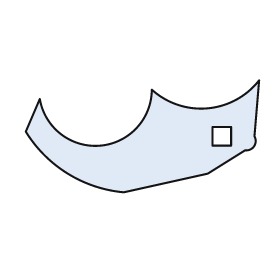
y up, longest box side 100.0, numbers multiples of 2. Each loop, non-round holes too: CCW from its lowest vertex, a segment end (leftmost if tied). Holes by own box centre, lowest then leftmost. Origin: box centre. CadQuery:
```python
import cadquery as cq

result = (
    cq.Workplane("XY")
    .moveTo(-8.0, -24.0)
    .lineTo(28.0, -16.0)
    .lineTo(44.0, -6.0)
    .threePointArc((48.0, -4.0), (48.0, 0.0))
    .lineTo(50.0, 24.0)
    .threePointArc((28.0, 12.0), (4.0, 20.0))
    .threePointArc((-18.0, -4.0), (-44.0, 16.0))
    .lineTo(-50.0, 2.0)
    .threePointArc((-32.0, -16.0), (-8.0, -24.0))
    .close()
    .moveTo(30.0, -4.0)
    .lineTo(38.0, -4.0)
    .lineTo(38.0, 4.0)
    .lineTo(30.0, 4.0)
    .close()
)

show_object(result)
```